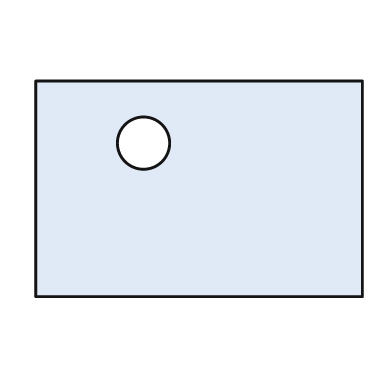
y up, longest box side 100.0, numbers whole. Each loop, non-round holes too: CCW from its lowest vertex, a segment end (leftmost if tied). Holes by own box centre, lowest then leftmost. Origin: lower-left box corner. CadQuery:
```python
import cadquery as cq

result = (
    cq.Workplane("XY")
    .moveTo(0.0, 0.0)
    .lineTo(100.0, 0.0)
    .lineTo(100.0, 66.0)
    .lineTo(0.0, 66.0)
    .close()
    .moveTo(33.0, 47.0)
    .circle(8.0)
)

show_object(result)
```